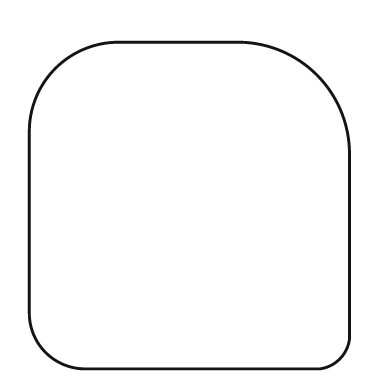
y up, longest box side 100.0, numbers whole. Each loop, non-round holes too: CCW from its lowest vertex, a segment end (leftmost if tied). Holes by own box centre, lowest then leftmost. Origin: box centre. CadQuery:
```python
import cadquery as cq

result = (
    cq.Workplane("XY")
    .moveTo(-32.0, -50.0)
    .lineTo(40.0, -50.0)
    .threePointArc((46.0, -47.0), (49.0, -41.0))
    .lineTo(49.0, 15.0)
    .threePointArc((39.0, 40.0), (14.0, 50.0))
    .lineTo(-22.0, 50.0)
    .threePointArc((-41.0, 42.0), (-49.0, 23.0))
    .lineTo(-49.0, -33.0)
    .threePointArc((-44.0, -45.0), (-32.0, -50.0))
    .close()
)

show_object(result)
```